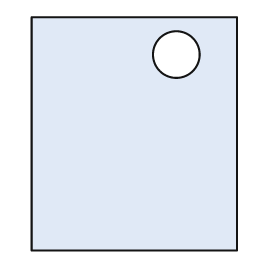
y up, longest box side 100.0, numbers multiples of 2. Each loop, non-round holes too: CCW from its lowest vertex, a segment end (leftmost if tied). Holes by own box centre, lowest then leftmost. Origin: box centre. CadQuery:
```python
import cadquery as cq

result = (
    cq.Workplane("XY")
    .moveTo(-44.0, -50.0)
    .lineTo(44.0, -50.0)
    .lineTo(44.0, 50.0)
    .lineTo(-44.0, 50.0)
    .close()
    .moveTo(18.0, 34.0)
    .circle(10.0)
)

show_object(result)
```